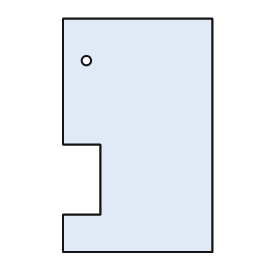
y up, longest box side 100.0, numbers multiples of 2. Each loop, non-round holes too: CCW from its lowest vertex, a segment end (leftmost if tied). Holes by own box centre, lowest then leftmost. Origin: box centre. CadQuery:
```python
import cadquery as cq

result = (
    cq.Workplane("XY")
    .moveTo(-32.0, -50.0)
    .lineTo(32.0, -50.0)
    .lineTo(32.0, 50.0)
    .lineTo(-32.0, 50.0)
    .lineTo(-32.0, -4.0)
    .lineTo(-16.0, -4.0)
    .lineTo(-16.0, -34.0)
    .lineTo(-32.0, -34.0)
    .close()
    .moveTo(-22.0, 32.0)
    .circle(2.0)
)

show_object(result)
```